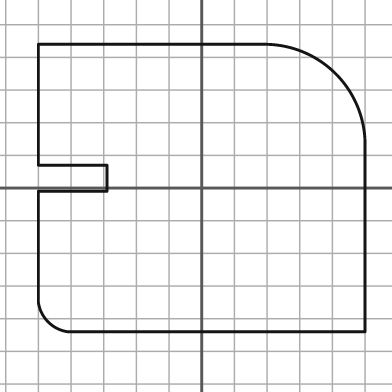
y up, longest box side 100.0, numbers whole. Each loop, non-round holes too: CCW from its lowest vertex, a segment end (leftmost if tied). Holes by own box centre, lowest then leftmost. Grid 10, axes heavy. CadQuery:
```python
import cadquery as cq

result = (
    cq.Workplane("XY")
    .moveTo(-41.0, -44.0)
    .lineTo(50.0, -44.0)
    .lineTo(50.0, 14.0)
    .threePointArc((41.0, 35.0), (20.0, 44.0))
    .lineTo(-50.0, 44.0)
    .lineTo(-50.0, 7.0)
    .lineTo(-29.0, 7.0)
    .lineTo(-29.0, -1.0)
    .lineTo(-50.0, -1.0)
    .lineTo(-50.0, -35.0)
    .threePointArc((-47.0, -41.0), (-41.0, -44.0))
    .close()
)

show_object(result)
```